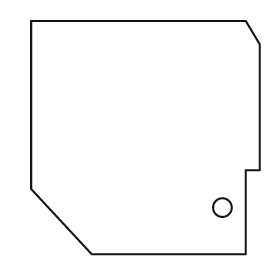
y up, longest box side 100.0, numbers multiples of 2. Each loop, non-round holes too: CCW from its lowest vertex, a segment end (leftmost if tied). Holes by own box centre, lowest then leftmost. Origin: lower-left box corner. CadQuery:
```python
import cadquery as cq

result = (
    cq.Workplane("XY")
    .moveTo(26.0, 0.0)
    .lineTo(92.0, 0.0)
    .lineTo(92.0, 36.0)
    .lineTo(98.0, 36.0)
    .lineTo(98.0, 90.0)
    .lineTo(92.0, 100.0)
    .lineTo(0.0, 100.0)
    .lineTo(0.0, 28.0)
    .close()
    .moveTo(82.0, 20.0)
    .circle(4.0)
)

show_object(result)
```